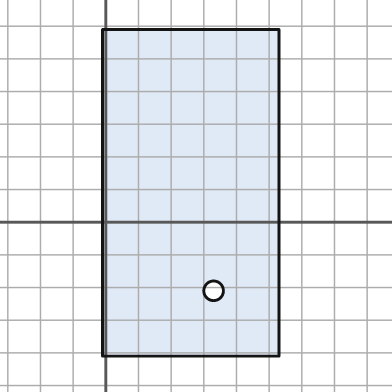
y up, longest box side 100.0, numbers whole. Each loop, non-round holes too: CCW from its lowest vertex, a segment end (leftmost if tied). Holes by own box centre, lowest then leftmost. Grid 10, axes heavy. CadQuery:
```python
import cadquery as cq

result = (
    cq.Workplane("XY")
    .moveTo(-1.0, -41.0)
    .lineTo(53.0, -41.0)
    .lineTo(53.0, 59.0)
    .lineTo(-1.0, 59.0)
    .close()
    .moveTo(33.0, -21.0)
    .circle(3.0)
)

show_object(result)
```